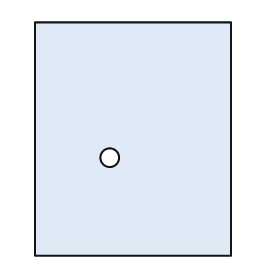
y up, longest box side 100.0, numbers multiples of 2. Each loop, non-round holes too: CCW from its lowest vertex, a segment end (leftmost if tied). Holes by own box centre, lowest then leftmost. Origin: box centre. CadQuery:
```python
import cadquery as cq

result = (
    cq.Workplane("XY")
    .moveTo(-42.0, -50.0)
    .lineTo(42.0, -50.0)
    .lineTo(42.0, 50.0)
    .lineTo(-42.0, 50.0)
    .close()
    .moveTo(-10.0, -8.0)
    .circle(4.0)
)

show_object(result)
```